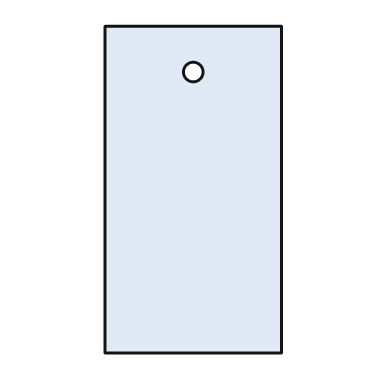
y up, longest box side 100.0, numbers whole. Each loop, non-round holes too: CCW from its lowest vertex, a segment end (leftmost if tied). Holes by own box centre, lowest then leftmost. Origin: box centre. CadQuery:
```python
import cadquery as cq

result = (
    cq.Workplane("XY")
    .moveTo(-27.0, -50.0)
    .lineTo(27.0, -50.0)
    .lineTo(27.0, 50.0)
    .lineTo(-27.0, 50.0)
    .close()
    .moveTo(0.0, 36.0)
    .circle(3.0)
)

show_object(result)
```